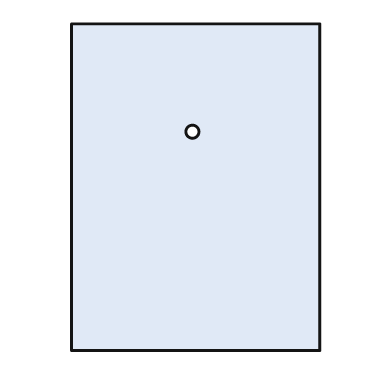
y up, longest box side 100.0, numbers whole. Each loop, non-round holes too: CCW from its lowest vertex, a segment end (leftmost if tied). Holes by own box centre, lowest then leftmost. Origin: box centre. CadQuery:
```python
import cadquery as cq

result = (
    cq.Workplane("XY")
    .moveTo(-38.0, -50.0)
    .lineTo(38.0, -50.0)
    .lineTo(38.0, 50.0)
    .lineTo(-38.0, 50.0)
    .close()
    .moveTo(-1.0, 17.0)
    .circle(2.0)
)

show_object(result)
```